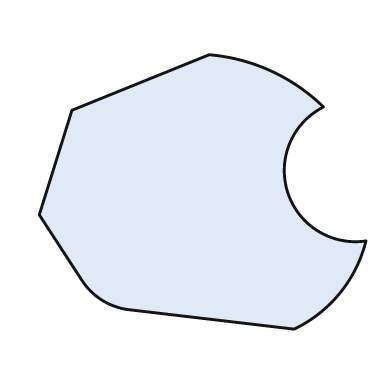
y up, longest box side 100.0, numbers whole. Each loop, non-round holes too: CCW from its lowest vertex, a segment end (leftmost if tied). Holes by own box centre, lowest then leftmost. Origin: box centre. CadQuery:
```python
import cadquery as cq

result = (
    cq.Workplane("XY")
    .moveTo(28.0, -42.0)
    .threePointArc((42.0, -31.0), (50.0, -15.0))
    .threePointArc((26.0, 0.0), (37.0, 26.0))
    .threePointArc((21.0, 37.0), (2.0, 42.0))
    .lineTo(-40.0, 25.0)
    .lineTo(-50.0, -7.0)
    .lineTo(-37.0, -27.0)
    .threePointArc((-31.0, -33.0), (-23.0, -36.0))
    .close()
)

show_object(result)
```